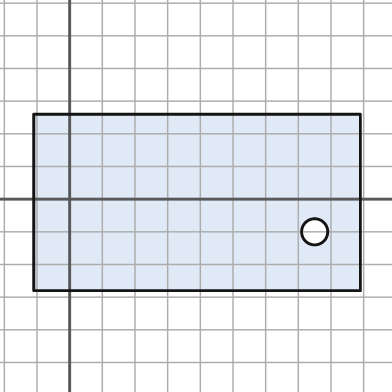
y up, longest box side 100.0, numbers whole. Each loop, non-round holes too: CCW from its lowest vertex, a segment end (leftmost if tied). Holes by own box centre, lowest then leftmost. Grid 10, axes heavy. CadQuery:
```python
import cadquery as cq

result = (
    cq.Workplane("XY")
    .moveTo(-11.0, -28.0)
    .lineTo(89.0, -28.0)
    .lineTo(89.0, 26.0)
    .lineTo(-11.0, 26.0)
    .close()
    .moveTo(75.0, -10.0)
    .circle(4.0)
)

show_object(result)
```